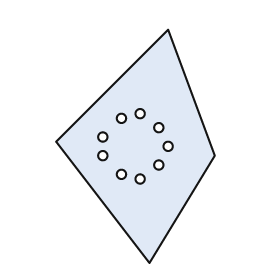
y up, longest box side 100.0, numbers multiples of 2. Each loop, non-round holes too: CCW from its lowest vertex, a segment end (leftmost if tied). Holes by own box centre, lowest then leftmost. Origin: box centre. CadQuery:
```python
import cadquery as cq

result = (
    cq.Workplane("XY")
    .moveTo(6.0, -50.0)
    .lineTo(34.0, -4.0)
    .lineTo(14.0, 50.0)
    .lineTo(-34.0, 2.0)
    .close()
    .moveTo(2.0, -14.0)
    .circle(2.0)
    .moveTo(-6.0, -12.0)
    .circle(2.0)
    .moveTo(10.0, -8.0)
    .circle(2.0)
    .moveTo(-14.0, -4.0)
    .circle(2.0)
    .moveTo(14.0, 0.0)
    .circle(2.0)
    .moveTo(-14.0, 4.0)
    .circle(2.0)
    .moveTo(10.0, 8.0)
    .circle(2.0)
    .moveTo(-6.0, 12.0)
    .circle(2.0)
    .moveTo(2.0, 14.0)
    .circle(2.0)
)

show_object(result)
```